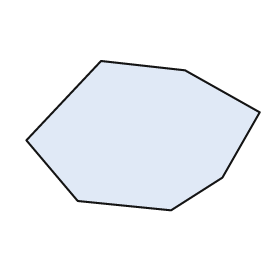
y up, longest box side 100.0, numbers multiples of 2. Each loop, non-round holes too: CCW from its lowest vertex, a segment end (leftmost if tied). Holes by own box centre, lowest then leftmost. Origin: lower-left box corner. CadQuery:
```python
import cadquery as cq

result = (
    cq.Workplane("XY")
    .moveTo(62.0, 0.0)
    .lineTo(84.0, 14.0)
    .lineTo(100.0, 42.0)
    .lineTo(68.0, 60.0)
    .lineTo(32.0, 64.0)
    .lineTo(0.0, 30.0)
    .lineTo(22.0, 4.0)
    .close()
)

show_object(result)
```